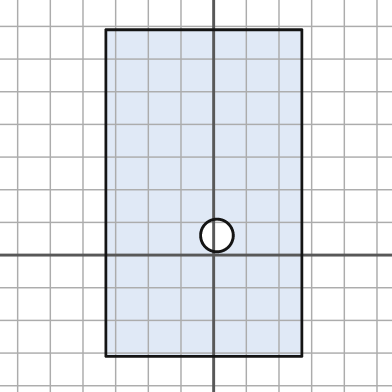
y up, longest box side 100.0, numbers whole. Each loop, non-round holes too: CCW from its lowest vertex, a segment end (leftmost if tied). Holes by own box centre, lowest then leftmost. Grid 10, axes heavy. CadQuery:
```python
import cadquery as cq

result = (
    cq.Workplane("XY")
    .moveTo(-33.0, -31.0)
    .lineTo(27.0, -31.0)
    .lineTo(27.0, 69.0)
    .lineTo(-33.0, 69.0)
    .close()
    .moveTo(1.0, 6.0)
    .circle(5.0)
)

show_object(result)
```